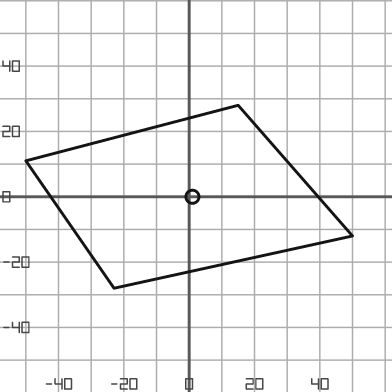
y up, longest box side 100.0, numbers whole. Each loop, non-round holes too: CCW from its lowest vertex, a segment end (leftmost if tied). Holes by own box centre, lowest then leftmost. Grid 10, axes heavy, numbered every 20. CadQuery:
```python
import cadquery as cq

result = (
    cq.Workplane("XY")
    .moveTo(-23.0, -28.0)
    .lineTo(50.0, -12.0)
    .lineTo(15.0, 28.0)
    .lineTo(-50.0, 11.0)
    .close()
    .moveTo(1.0, 0.0)
    .circle(2.0)
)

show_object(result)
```